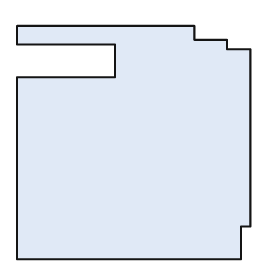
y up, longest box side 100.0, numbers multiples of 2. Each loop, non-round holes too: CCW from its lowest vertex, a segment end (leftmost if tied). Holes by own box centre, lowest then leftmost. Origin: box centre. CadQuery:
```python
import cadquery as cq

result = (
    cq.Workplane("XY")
    .moveTo(-50.0, -50.0)
    .lineTo(46.0, -50.0)
    .lineTo(46.0, -36.0)
    .lineTo(50.0, -36.0)
    .lineTo(50.0, 40.0)
    .lineTo(40.0, 40.0)
    .lineTo(40.0, 44.0)
    .lineTo(26.0, 44.0)
    .lineTo(26.0, 50.0)
    .lineTo(-50.0, 50.0)
    .lineTo(-50.0, 42.0)
    .lineTo(-8.0, 42.0)
    .lineTo(-8.0, 28.0)
    .lineTo(-50.0, 28.0)
    .close()
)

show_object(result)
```